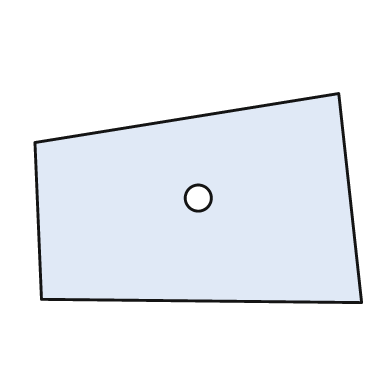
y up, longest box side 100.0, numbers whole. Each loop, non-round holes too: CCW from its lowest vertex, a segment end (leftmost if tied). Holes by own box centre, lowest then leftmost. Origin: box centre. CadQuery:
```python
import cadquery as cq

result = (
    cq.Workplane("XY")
    .moveTo(50.0, -32.0)
    .lineTo(43.0, 32.0)
    .lineTo(-50.0, 17.0)
    .lineTo(-48.0, -31.0)
    .close()
    .moveTo(0.0, 0.0)
    .circle(4.0)
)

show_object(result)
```